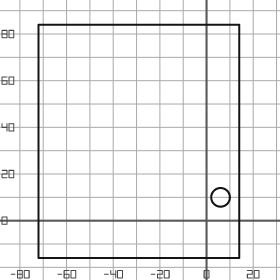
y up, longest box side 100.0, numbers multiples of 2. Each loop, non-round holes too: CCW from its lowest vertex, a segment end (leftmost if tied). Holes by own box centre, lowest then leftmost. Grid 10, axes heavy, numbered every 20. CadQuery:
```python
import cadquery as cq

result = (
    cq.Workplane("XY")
    .moveTo(-72.0, -16.0)
    .lineTo(14.0, -16.0)
    .lineTo(14.0, 84.0)
    .lineTo(-72.0, 84.0)
    .close()
    .moveTo(6.0, 10.0)
    .circle(4.0)
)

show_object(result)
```